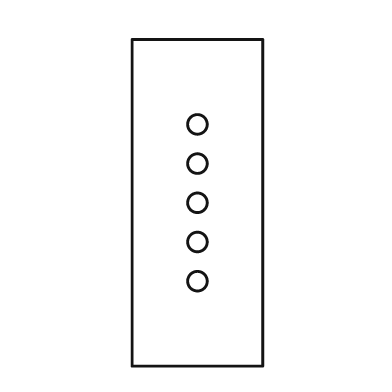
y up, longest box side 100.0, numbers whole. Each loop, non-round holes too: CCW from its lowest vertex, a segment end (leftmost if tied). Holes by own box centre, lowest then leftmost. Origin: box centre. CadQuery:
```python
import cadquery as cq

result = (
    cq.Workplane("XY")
    .moveTo(-20.0, -50.0)
    .lineTo(20.0, -50.0)
    .lineTo(20.0, 50.0)
    .lineTo(-20.0, 50.0)
    .close()
    .moveTo(0.0, -24.0)
    .circle(3.0)
    .moveTo(0.0, -12.0)
    .circle(3.0)
    .moveTo(0.0, 0.0)
    .circle(3.0)
    .moveTo(0.0, 12.0)
    .circle(3.0)
    .moveTo(0.0, 24.0)
    .circle(3.0)
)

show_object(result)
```